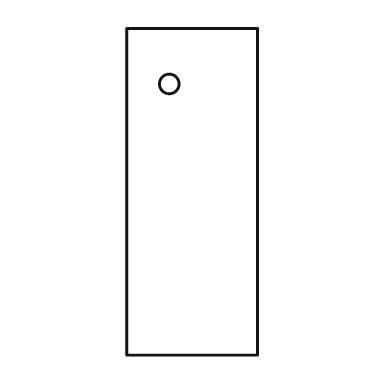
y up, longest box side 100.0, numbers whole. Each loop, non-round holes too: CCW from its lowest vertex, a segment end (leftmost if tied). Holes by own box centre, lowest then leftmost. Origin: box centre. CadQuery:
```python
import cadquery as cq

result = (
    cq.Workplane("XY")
    .moveTo(-20.0, -50.0)
    .lineTo(20.0, -50.0)
    .lineTo(20.0, 50.0)
    .lineTo(-20.0, 50.0)
    .close()
    .moveTo(-7.0, 33.0)
    .circle(3.0)
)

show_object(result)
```